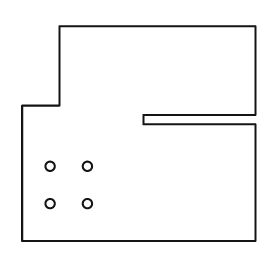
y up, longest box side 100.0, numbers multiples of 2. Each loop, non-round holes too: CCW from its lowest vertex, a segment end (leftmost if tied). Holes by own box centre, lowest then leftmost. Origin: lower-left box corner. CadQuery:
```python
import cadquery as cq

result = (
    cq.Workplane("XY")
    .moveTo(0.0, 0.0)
    .lineTo(100.0, 0.0)
    .lineTo(100.0, 50.0)
    .lineTo(52.0, 50.0)
    .lineTo(52.0, 54.0)
    .lineTo(100.0, 54.0)
    .lineTo(100.0, 92.0)
    .lineTo(16.0, 92.0)
    .lineTo(16.0, 58.0)
    .lineTo(0.0, 58.0)
    .close()
    .moveTo(12.0, 16.0)
    .circle(2.0)
    .moveTo(28.0, 16.0)
    .circle(2.0)
    .moveTo(12.0, 32.0)
    .circle(2.0)
    .moveTo(28.0, 32.0)
    .circle(2.0)
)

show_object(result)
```